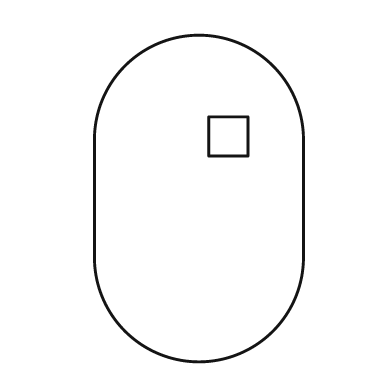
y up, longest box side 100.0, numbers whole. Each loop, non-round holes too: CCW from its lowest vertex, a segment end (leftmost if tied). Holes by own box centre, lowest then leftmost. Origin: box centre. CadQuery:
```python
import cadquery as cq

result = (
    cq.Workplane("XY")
    .moveTo(-32.0, -18.0)
    .threePointArc((0.0, -50.0), (32.0, -18.0))
    .lineTo(32.0, 18.0)
    .threePointArc((0.0, 50.0), (-32.0, 18.0))
    .close()
    .moveTo(3.0, 13.0)
    .lineTo(15.0, 13.0)
    .lineTo(15.0, 25.0)
    .lineTo(3.0, 25.0)
    .close()
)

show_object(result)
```